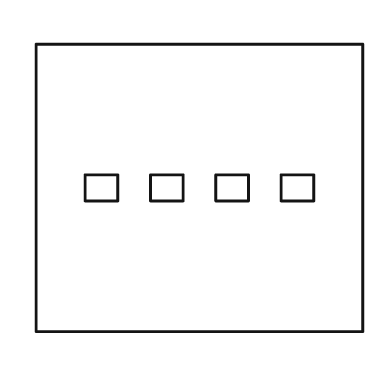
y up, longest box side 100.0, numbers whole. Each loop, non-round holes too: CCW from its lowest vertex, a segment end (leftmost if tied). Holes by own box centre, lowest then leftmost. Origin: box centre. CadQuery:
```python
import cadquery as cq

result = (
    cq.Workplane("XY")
    .moveTo(-50.0, -44.0)
    .lineTo(50.0, -44.0)
    .lineTo(50.0, 44.0)
    .lineTo(-50.0, 44.0)
    .close()
    .moveTo(-35.0, -4.0)
    .lineTo(-25.0, -4.0)
    .lineTo(-25.0, 4.0)
    .lineTo(-35.0, 4.0)
    .close()
    .moveTo(-15.0, -4.0)
    .lineTo(-5.0, -4.0)
    .lineTo(-5.0, 4.0)
    .lineTo(-15.0, 4.0)
    .close()
    .moveTo(5.0, -4.0)
    .lineTo(15.0, -4.0)
    .lineTo(15.0, 4.0)
    .lineTo(5.0, 4.0)
    .close()
    .moveTo(25.0, -4.0)
    .lineTo(35.0, -4.0)
    .lineTo(35.0, 4.0)
    .lineTo(25.0, 4.0)
    .close()
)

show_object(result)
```